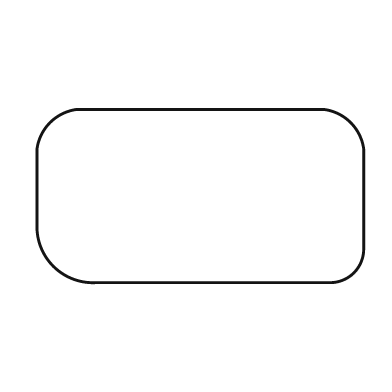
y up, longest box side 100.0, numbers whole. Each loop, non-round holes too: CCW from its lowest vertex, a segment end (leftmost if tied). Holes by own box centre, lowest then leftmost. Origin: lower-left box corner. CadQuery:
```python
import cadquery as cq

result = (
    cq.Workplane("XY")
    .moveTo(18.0, 0.0)
    .lineTo(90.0, 0.0)
    .threePointArc((97.0, 3.0), (100.0, 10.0))
    .lineTo(100.0, 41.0)
    .threePointArc((96.0, 49.0), (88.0, 53.0))
    .lineTo(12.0, 53.0)
    .threePointArc((4.0, 49.0), (0.0, 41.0))
    .lineTo(0.0, 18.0)
    .threePointArc((5.0, 5.0), (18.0, 0.0))
    .close()
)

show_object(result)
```